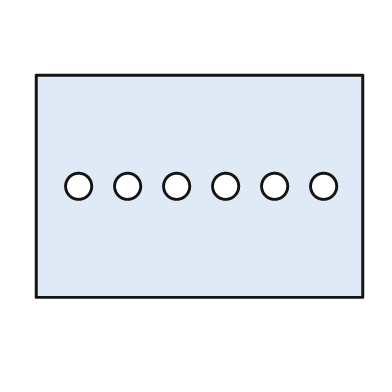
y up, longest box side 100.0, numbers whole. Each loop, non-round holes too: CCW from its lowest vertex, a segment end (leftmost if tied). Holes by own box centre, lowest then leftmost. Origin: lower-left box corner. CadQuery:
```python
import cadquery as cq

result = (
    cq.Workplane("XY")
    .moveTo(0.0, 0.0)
    .lineTo(100.0, 0.0)
    .lineTo(100.0, 68.0)
    .lineTo(0.0, 68.0)
    .close()
    .moveTo(13.0, 34.0)
    .circle(4.0)
    .moveTo(28.0, 34.0)
    .circle(4.0)
    .moveTo(43.0, 34.0)
    .circle(4.0)
    .moveTo(58.0, 34.0)
    .circle(4.0)
    .moveTo(73.0, 34.0)
    .circle(4.0)
    .moveTo(88.0, 34.0)
    .circle(4.0)
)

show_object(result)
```